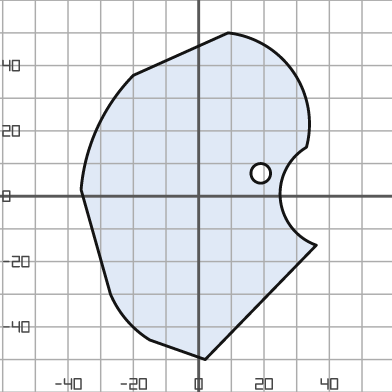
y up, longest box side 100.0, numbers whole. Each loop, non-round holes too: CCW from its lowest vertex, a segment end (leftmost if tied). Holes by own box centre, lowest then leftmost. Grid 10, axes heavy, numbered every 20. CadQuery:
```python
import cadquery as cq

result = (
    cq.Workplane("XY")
    .moveTo(2.0, -50.0)
    .lineTo(36.0, -15.0)
    .threePointArc((25.0, -1.0), (33.0, 15.0))
    .threePointArc((29.0, 38.0), (9.0, 50.0))
    .lineTo(-20.0, 37.0)
    .threePointArc((-31.0, 21.0), (-36.0, 2.0))
    .lineTo(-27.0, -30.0)
    .threePointArc((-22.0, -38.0), (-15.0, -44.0))
    .close()
    .moveTo(19.0, 7.0)
    .circle(3.0)
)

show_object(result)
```